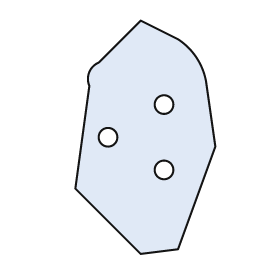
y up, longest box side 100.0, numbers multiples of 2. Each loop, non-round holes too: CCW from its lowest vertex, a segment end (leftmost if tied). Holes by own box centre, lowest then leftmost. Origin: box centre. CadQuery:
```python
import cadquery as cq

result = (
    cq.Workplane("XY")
    .moveTo(-2.0, -50.0)
    .lineTo(14.0, -48.0)
    .lineTo(30.0, -4.0)
    .lineTo(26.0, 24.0)
    .threePointArc((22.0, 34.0), (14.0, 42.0))
    .lineTo(-2.0, 50.0)
    .lineTo(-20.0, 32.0)
    .threePointArc((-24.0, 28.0), (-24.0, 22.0))
    .lineTo(-30.0, -22.0)
    .close()
    .moveTo(8.0, -14.0)
    .circle(4.0)
    .moveTo(-16.0, 0.0)
    .circle(4.0)
    .moveTo(8.0, 14.0)
    .circle(4.0)
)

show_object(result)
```